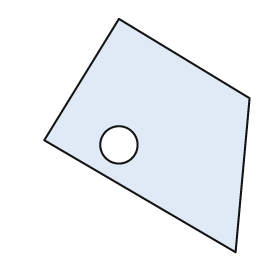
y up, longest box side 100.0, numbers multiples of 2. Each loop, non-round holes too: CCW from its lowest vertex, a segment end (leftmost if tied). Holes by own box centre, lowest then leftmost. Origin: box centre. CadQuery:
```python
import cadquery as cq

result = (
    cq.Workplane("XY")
    .moveTo(38.0, -50.0)
    .lineTo(44.0, 16.0)
    .lineTo(-12.0, 50.0)
    .lineTo(-44.0, -2.0)
    .close()
    .moveTo(-12.0, -4.0)
    .circle(8.0)
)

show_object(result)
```